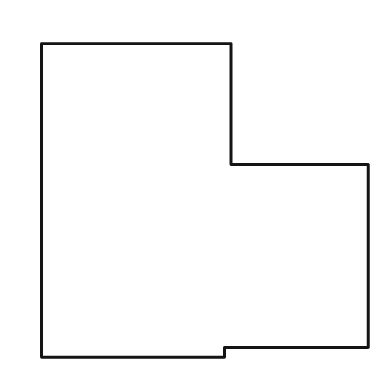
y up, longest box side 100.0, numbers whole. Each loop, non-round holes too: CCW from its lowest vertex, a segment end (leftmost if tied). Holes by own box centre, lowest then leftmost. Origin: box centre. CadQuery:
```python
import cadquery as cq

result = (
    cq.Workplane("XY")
    .moveTo(-50.0, -48.0)
    .lineTo(6.0, -48.0)
    .lineTo(6.0, -45.0)
    .lineTo(50.0, -45.0)
    .lineTo(50.0, 11.0)
    .lineTo(8.0, 11.0)
    .lineTo(8.0, 48.0)
    .lineTo(-50.0, 48.0)
    .close()
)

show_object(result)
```